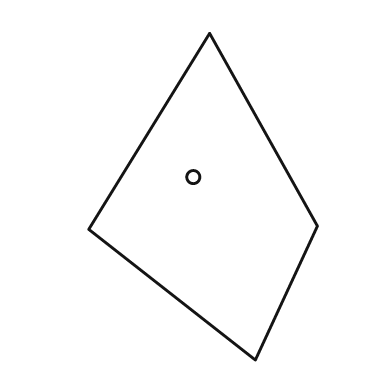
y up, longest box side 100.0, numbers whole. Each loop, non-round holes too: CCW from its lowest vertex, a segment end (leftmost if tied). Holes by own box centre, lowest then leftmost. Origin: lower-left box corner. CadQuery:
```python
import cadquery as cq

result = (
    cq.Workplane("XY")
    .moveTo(51.0, 0.0)
    .lineTo(70.0, 41.0)
    .lineTo(37.0, 100.0)
    .lineTo(0.0, 40.0)
    .close()
    .moveTo(32.0, 56.0)
    .circle(2.0)
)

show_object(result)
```